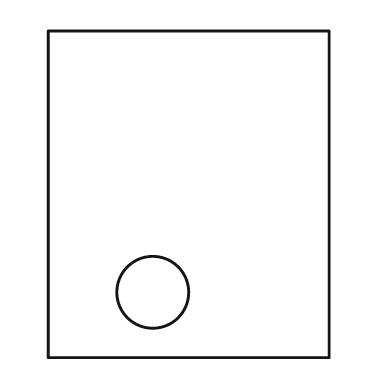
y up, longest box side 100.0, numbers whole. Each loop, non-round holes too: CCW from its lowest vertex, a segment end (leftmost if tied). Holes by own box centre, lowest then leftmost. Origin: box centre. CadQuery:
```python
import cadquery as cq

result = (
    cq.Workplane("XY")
    .moveTo(-43.0, -50.0)
    .lineTo(43.0, -50.0)
    .lineTo(43.0, 50.0)
    .lineTo(-43.0, 50.0)
    .close()
    .moveTo(-11.0, -30.0)
    .circle(11.0)
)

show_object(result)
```